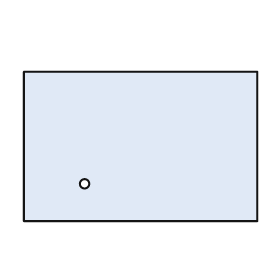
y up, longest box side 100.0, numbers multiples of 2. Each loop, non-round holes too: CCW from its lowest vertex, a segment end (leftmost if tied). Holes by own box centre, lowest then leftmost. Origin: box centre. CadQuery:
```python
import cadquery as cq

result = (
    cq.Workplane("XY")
    .moveTo(-50.0, -32.0)
    .lineTo(50.0, -32.0)
    .lineTo(50.0, 32.0)
    .lineTo(-50.0, 32.0)
    .close()
    .moveTo(-24.0, -16.0)
    .circle(2.0)
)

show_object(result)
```